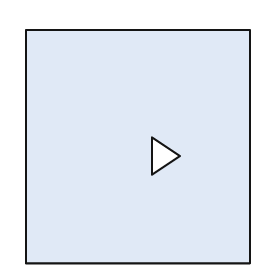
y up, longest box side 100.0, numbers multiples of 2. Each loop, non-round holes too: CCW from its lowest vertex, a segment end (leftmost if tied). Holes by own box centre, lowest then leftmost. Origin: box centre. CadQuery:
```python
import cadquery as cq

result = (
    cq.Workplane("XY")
    .moveTo(-48.0, -50.0)
    .lineTo(48.0, -50.0)
    .lineTo(48.0, 50.0)
    .lineTo(-48.0, 50.0)
    .close()
    .moveTo(6.0, -12.0)
    .lineTo(18.0, -4.0)
    .lineTo(6.0, 4.0)
    .close()
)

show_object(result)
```